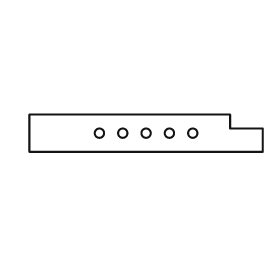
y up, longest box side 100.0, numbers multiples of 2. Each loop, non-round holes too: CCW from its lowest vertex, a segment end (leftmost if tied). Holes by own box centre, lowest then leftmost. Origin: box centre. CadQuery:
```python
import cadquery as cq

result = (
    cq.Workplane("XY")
    .moveTo(-50.0, -8.0)
    .lineTo(50.0, -8.0)
    .lineTo(50.0, 2.0)
    .lineTo(36.0, 2.0)
    .lineTo(36.0, 8.0)
    .lineTo(-50.0, 8.0)
    .close()
    .moveTo(-20.0, 0.0)
    .circle(2.0)
    .moveTo(-10.0, 0.0)
    .circle(2.0)
    .moveTo(0.0, 0.0)
    .circle(2.0)
    .moveTo(10.0, 0.0)
    .circle(2.0)
    .moveTo(20.0, 0.0)
    .circle(2.0)
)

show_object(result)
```